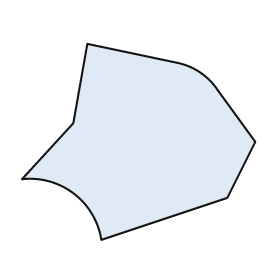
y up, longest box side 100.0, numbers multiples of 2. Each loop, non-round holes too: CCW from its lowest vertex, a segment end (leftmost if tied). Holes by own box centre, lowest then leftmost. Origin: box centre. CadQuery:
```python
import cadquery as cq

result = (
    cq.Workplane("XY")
    .moveTo(-16.0, -42.0)
    .lineTo(38.0, -24.0)
    .lineTo(50.0, 0.0)
    .lineTo(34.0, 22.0)
    .threePointArc((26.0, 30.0), (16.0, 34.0))
    .lineTo(-22.0, 42.0)
    .lineTo(-28.0, 8.0)
    .lineTo(-50.0, -16.0)
    .threePointArc((-28.0, -22.0), (-16.0, -42.0))
    .close()
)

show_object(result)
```